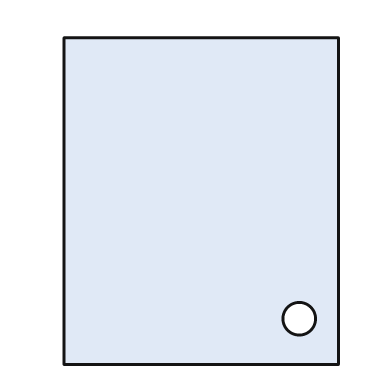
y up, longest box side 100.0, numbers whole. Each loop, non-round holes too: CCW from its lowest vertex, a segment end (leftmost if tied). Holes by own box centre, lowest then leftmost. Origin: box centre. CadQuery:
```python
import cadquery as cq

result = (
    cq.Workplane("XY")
    .moveTo(-42.0, -50.0)
    .lineTo(42.0, -50.0)
    .lineTo(42.0, 50.0)
    .lineTo(-42.0, 50.0)
    .close()
    .moveTo(30.0, -36.0)
    .circle(5.0)
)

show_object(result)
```